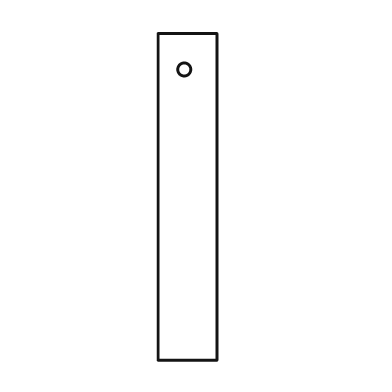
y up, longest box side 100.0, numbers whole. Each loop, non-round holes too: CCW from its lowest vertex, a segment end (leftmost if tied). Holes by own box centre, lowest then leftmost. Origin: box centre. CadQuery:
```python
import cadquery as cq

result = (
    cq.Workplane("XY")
    .moveTo(-9.0, -50.0)
    .lineTo(9.0, -50.0)
    .lineTo(9.0, 50.0)
    .lineTo(-9.0, 50.0)
    .close()
    .moveTo(-1.0, 39.0)
    .circle(2.0)
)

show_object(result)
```